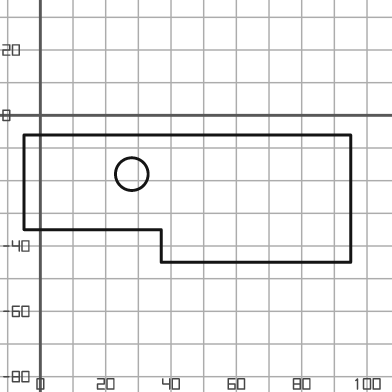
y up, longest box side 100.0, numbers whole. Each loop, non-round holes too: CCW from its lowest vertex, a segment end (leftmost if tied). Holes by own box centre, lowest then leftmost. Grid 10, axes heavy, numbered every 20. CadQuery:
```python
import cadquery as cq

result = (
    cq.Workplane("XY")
    .moveTo(37.0, -45.0)
    .lineTo(95.0, -45.0)
    .lineTo(95.0, -6.0)
    .lineTo(-5.0, -6.0)
    .lineTo(-5.0, -35.0)
    .lineTo(37.0, -35.0)
    .close()
    .moveTo(28.0, -18.0)
    .circle(5.0)
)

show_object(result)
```